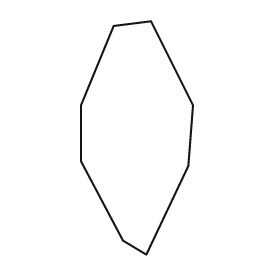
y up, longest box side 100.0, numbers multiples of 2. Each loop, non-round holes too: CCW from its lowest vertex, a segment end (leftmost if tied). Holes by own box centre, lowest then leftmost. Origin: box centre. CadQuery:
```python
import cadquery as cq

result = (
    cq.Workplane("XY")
    .moveTo(4.0, -50.0)
    .lineTo(22.0, -12.0)
    .lineTo(24.0, 14.0)
    .lineTo(6.0, 50.0)
    .lineTo(-10.0, 48.0)
    .lineTo(-24.0, 14.0)
    .lineTo(-24.0, -10.0)
    .lineTo(-6.0, -44.0)
    .close()
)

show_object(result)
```